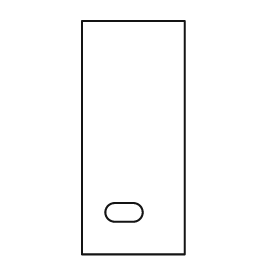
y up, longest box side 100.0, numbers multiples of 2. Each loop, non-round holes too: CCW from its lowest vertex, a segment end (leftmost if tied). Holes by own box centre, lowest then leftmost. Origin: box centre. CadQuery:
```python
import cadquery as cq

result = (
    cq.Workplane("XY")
    .moveTo(-22.0, -50.0)
    .lineTo(22.0, -50.0)
    .lineTo(22.0, 50.0)
    .lineTo(-22.0, 50.0)
    .close()
    .moveTo(-8.0, -36.0)
    .lineTo(0.0, -36.0)
    .threePointArc((4.0, -32.0), (0.0, -28.0))
    .lineTo(-8.0, -28.0)
    .threePointArc((-12.0, -32.0), (-8.0, -36.0))
    .close()
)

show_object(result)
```